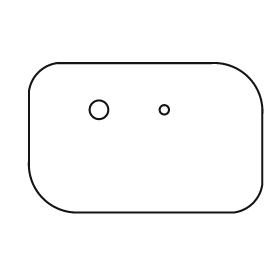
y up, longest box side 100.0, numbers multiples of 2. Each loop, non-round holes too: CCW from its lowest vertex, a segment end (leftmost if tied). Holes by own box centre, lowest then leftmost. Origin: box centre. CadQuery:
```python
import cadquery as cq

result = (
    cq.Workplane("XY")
    .moveTo(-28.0, -32.0)
    .lineTo(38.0, -32.0)
    .threePointArc((46.0, -28.0), (50.0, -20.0))
    .lineTo(50.0, 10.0)
    .threePointArc((44.0, 26.0), (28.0, 32.0))
    .lineTo(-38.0, 32.0)
    .threePointArc((-46.0, 28.0), (-50.0, 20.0))
    .lineTo(-50.0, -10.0)
    .threePointArc((-44.0, -26.0), (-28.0, -32.0))
    .close()
    .moveTo(-20.0, 12.0)
    .circle(4.0)
    .moveTo(8.0, 12.0)
    .circle(2.0)
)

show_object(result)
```